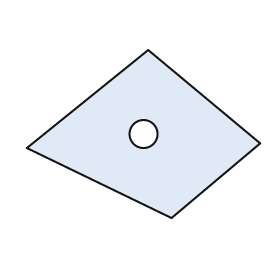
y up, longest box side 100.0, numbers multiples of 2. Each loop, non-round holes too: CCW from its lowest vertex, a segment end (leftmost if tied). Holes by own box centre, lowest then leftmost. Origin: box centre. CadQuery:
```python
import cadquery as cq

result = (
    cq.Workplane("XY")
    .moveTo(12.0, -36.0)
    .lineTo(50.0, -4.0)
    .lineTo(2.0, 36.0)
    .lineTo(-50.0, -6.0)
    .close()
    .moveTo(0.0, 0.0)
    .circle(6.0)
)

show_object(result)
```